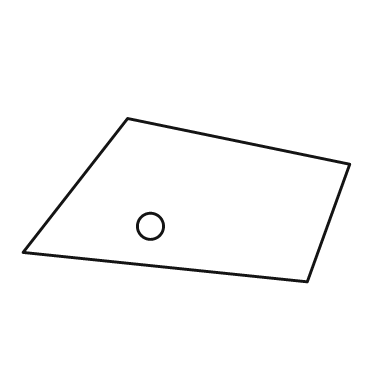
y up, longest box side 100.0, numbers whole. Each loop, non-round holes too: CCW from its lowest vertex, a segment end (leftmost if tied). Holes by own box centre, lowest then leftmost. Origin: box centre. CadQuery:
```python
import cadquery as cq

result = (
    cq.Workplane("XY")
    .moveTo(37.0, -25.0)
    .lineTo(50.0, 11.0)
    .lineTo(-18.0, 25.0)
    .lineTo(-50.0, -16.0)
    .close()
    .moveTo(-11.0, -8.0)
    .circle(4.0)
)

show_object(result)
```